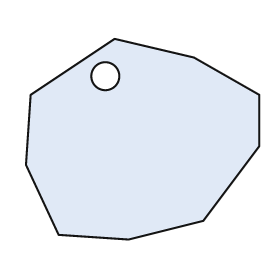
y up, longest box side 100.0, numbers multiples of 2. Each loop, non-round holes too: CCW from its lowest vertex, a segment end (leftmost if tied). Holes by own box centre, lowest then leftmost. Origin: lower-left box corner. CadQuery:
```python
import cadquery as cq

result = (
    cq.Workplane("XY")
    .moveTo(44.0, 0.0)
    .lineTo(76.0, 8.0)
    .lineTo(100.0, 40.0)
    .lineTo(100.0, 62.0)
    .lineTo(72.0, 78.0)
    .lineTo(38.0, 86.0)
    .lineTo(2.0, 62.0)
    .lineTo(0.0, 32.0)
    .lineTo(14.0, 2.0)
    .close()
    .moveTo(34.0, 70.0)
    .circle(6.0)
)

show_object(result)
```